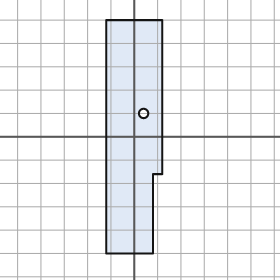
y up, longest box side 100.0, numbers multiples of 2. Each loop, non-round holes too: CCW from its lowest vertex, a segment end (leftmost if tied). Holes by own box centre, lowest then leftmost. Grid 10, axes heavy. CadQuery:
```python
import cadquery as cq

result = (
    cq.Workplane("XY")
    .moveTo(-12.0, -50.0)
    .lineTo(8.0, -50.0)
    .lineTo(8.0, -16.0)
    .lineTo(12.0, -16.0)
    .lineTo(12.0, 50.0)
    .lineTo(-12.0, 50.0)
    .close()
    .moveTo(4.0, 10.0)
    .circle(2.0)
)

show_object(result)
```